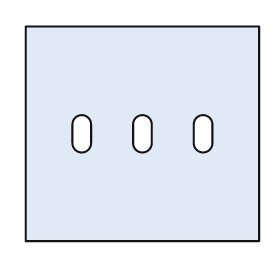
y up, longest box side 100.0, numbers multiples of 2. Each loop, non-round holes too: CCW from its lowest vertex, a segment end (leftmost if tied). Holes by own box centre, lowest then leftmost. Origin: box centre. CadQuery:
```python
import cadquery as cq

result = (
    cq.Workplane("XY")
    .moveTo(-50.0, -46.0)
    .lineTo(50.0, -46.0)
    .lineTo(50.0, 46.0)
    .lineTo(-50.0, 46.0)
    .close()
    .moveTo(-30.0, -4.0)
    .threePointArc((-26.0, -8.0), (-22.0, -4.0))
    .lineTo(-22.0, 4.0)
    .threePointArc((-26.0, 8.0), (-30.0, 4.0))
    .close()
    .moveTo(-4.0, -4.0)
    .threePointArc((0.0, -8.0), (4.0, -4.0))
    .lineTo(4.0, 4.0)
    .threePointArc((0.0, 8.0), (-4.0, 4.0))
    .close()
    .moveTo(22.0, -4.0)
    .threePointArc((26.0, -8.0), (30.0, -4.0))
    .lineTo(30.0, 4.0)
    .threePointArc((26.0, 8.0), (22.0, 4.0))
    .close()
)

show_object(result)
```